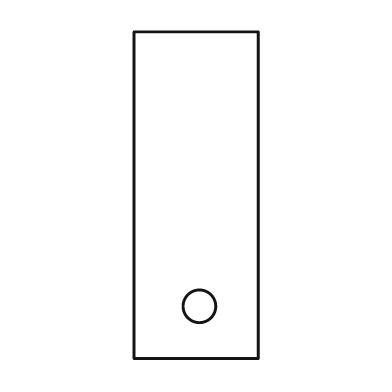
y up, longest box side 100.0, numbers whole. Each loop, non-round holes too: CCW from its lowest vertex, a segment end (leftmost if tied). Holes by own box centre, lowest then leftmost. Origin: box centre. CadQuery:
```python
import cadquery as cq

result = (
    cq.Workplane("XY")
    .moveTo(-19.0, -50.0)
    .lineTo(19.0, -50.0)
    .lineTo(19.0, 50.0)
    .lineTo(-19.0, 50.0)
    .close()
    .moveTo(1.0, -34.0)
    .circle(5.0)
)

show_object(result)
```